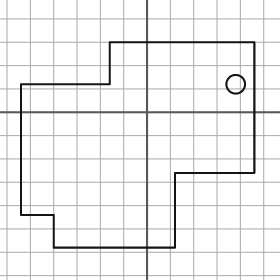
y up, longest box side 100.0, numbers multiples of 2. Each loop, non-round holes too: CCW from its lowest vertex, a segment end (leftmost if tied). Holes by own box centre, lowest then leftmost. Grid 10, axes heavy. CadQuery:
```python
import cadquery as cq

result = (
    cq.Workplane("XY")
    .moveTo(-40.0, -58.0)
    .lineTo(12.0, -58.0)
    .lineTo(12.0, -26.0)
    .lineTo(46.0, -26.0)
    .lineTo(46.0, 30.0)
    .lineTo(-16.0, 30.0)
    .lineTo(-16.0, 12.0)
    .lineTo(-54.0, 12.0)
    .lineTo(-54.0, -44.0)
    .lineTo(-40.0, -44.0)
    .close()
    .moveTo(38.0, 12.0)
    .circle(4.0)
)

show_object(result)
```